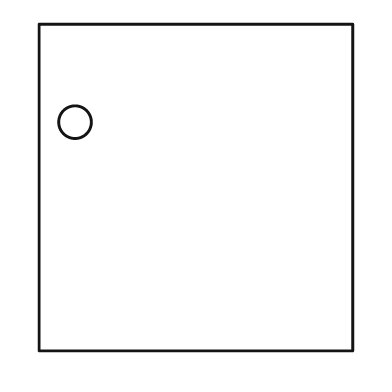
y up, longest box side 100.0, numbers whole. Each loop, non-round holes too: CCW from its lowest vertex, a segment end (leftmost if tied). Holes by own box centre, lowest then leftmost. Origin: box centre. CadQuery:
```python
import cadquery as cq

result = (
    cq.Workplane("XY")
    .moveTo(-48.0, -50.0)
    .lineTo(48.0, -50.0)
    .lineTo(48.0, 50.0)
    .lineTo(-48.0, 50.0)
    .close()
    .moveTo(-37.0, 20.0)
    .circle(5.0)
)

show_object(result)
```